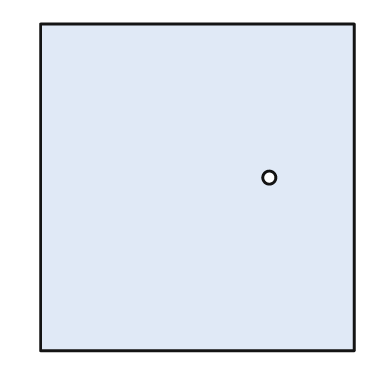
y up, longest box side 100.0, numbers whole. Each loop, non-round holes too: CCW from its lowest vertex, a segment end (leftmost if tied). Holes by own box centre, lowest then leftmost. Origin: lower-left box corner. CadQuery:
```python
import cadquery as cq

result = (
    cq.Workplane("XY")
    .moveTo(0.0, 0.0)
    .lineTo(96.0, 0.0)
    .lineTo(96.0, 100.0)
    .lineTo(0.0, 100.0)
    .close()
    .moveTo(70.0, 53.0)
    .circle(2.0)
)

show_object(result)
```